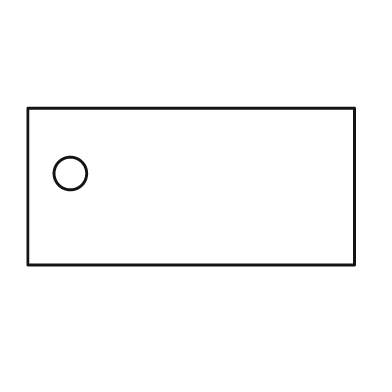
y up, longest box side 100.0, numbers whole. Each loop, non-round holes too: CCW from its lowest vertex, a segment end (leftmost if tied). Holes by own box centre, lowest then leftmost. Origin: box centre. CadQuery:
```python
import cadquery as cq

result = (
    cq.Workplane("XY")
    .moveTo(-50.0, -24.0)
    .lineTo(50.0, -24.0)
    .lineTo(50.0, 24.0)
    .lineTo(-50.0, 24.0)
    .close()
    .moveTo(-37.0, 4.0)
    .circle(5.0)
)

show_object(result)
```